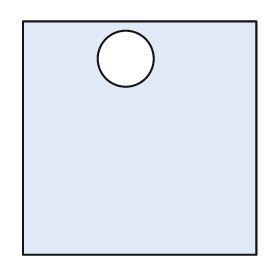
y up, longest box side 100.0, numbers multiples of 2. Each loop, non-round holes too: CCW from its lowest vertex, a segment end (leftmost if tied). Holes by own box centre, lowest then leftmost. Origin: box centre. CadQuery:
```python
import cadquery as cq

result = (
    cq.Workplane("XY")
    .moveTo(-50.0, -50.0)
    .lineTo(50.0, -50.0)
    .lineTo(50.0, 50.0)
    .lineTo(-50.0, 50.0)
    .close()
    .moveTo(-6.0, 34.0)
    .circle(12.0)
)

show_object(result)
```